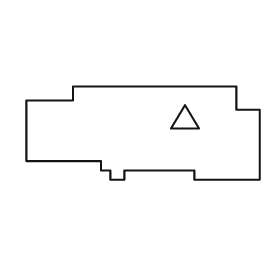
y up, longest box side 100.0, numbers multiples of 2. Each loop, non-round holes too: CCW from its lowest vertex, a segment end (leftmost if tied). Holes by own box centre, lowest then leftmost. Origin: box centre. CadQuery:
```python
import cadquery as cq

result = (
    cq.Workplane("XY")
    .moveTo(-14.0, -20.0)
    .lineTo(-8.0, -20.0)
    .lineTo(-8.0, -16.0)
    .lineTo(22.0, -16.0)
    .lineTo(22.0, -20.0)
    .lineTo(50.0, -20.0)
    .lineTo(50.0, 10.0)
    .lineTo(40.0, 10.0)
    .lineTo(40.0, 20.0)
    .lineTo(-30.0, 20.0)
    .lineTo(-30.0, 14.0)
    .lineTo(-50.0, 14.0)
    .lineTo(-50.0, -12.0)
    .lineTo(-18.0, -12.0)
    .lineTo(-18.0, -16.0)
    .lineTo(-14.0, -16.0)
    .close()
    .moveTo(12.0, 2.0)
    .lineTo(24.0, 2.0)
    .lineTo(18.0, 12.0)
    .close()
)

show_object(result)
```